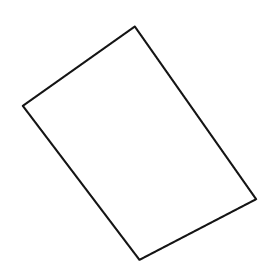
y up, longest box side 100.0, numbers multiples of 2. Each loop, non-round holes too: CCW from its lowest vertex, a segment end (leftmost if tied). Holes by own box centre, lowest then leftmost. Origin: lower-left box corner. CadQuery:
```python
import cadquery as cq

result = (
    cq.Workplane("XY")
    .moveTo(50.0, 0.0)
    .lineTo(100.0, 26.0)
    .lineTo(48.0, 100.0)
    .lineTo(0.0, 66.0)
    .close()
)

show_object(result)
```